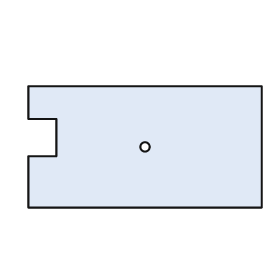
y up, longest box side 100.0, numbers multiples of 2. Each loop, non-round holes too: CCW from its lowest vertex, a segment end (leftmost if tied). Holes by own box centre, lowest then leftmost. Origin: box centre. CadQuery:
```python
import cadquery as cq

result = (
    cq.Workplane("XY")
    .moveTo(-50.0, -26.0)
    .lineTo(50.0, -26.0)
    .lineTo(50.0, 26.0)
    .lineTo(-50.0, 26.0)
    .lineTo(-50.0, 12.0)
    .lineTo(-38.0, 12.0)
    .lineTo(-38.0, -4.0)
    .lineTo(-50.0, -4.0)
    .close()
    .moveTo(0.0, 0.0)
    .circle(2.0)
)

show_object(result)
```